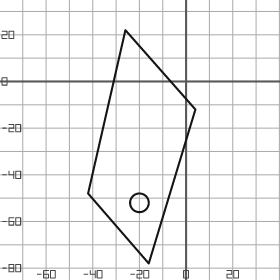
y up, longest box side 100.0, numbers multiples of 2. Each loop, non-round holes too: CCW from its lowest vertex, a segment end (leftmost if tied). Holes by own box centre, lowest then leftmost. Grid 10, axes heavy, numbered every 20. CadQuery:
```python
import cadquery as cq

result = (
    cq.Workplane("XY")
    .moveTo(-16.0, -78.0)
    .lineTo(4.0, -12.0)
    .lineTo(-26.0, 22.0)
    .lineTo(-42.0, -48.0)
    .close()
    .moveTo(-20.0, -52.0)
    .circle(4.0)
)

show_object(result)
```